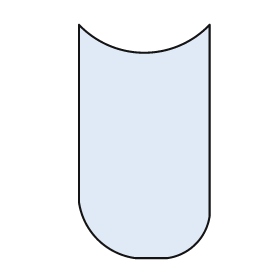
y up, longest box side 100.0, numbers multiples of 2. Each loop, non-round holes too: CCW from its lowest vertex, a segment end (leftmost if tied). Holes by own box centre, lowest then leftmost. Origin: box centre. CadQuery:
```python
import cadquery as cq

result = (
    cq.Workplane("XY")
    .moveTo(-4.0, -50.0)
    .lineTo(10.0, -50.0)
    .threePointArc((22.0, -44.0), (28.0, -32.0))
    .lineTo(28.0, 50.0)
    .threePointArc((0.0, 38.0), (-28.0, 50.0))
    .lineTo(-28.0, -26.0)
    .threePointArc((-20.0, -42.0), (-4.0, -50.0))
    .close()
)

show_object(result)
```